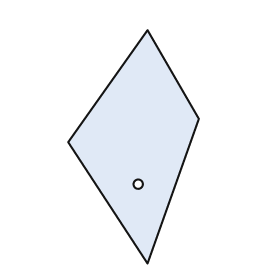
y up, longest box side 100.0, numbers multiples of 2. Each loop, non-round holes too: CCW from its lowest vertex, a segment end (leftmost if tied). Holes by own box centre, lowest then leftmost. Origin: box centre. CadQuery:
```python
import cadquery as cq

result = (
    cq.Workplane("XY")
    .moveTo(6.0, -50.0)
    .lineTo(28.0, 12.0)
    .lineTo(6.0, 50.0)
    .lineTo(-28.0, 2.0)
    .close()
    .moveTo(2.0, -16.0)
    .circle(2.0)
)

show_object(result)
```